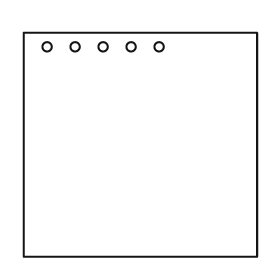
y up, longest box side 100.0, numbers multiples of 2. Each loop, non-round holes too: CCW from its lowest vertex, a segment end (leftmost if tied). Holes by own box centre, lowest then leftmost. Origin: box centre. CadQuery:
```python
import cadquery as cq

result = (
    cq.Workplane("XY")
    .moveTo(-50.0, -48.0)
    .lineTo(50.0, -48.0)
    .lineTo(50.0, 48.0)
    .lineTo(-50.0, 48.0)
    .close()
    .moveTo(-40.0, 42.0)
    .circle(2.0)
    .moveTo(-28.0, 42.0)
    .circle(2.0)
    .moveTo(-16.0, 42.0)
    .circle(2.0)
    .moveTo(-4.0, 42.0)
    .circle(2.0)
    .moveTo(8.0, 42.0)
    .circle(2.0)
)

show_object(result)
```